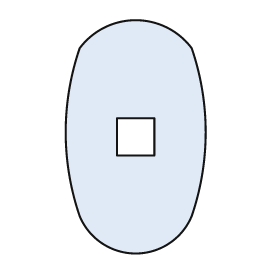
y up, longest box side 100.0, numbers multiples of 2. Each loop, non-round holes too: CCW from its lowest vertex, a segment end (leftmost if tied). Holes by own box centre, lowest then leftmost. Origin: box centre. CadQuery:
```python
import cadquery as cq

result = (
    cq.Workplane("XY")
    .moveTo(-24.0, -34.0)
    .threePointArc((0.0, -50.0), (24.0, -34.0))
    .threePointArc((30.0, 2.0), (24.0, 38.0))
    .threePointArc((0.0, 50.0), (-24.0, 38.0))
    .threePointArc((-30.0, 2.0), (-24.0, -34.0))
    .close()
    .moveTo(-8.0, -8.0)
    .lineTo(8.0, -8.0)
    .lineTo(8.0, 8.0)
    .lineTo(-8.0, 8.0)
    .close()
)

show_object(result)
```